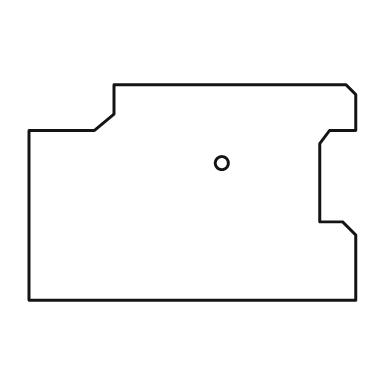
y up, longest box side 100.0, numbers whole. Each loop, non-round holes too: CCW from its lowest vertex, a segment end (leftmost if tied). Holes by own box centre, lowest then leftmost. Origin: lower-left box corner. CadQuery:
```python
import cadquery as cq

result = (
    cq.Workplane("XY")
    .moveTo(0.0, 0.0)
    .lineTo(100.0, 0.0)
    .lineTo(100.0, 20.0)
    .lineTo(96.0, 24.0)
    .lineTo(89.0, 24.0)
    .lineTo(89.0, 48.0)
    .lineTo(92.0, 52.0)
    .lineTo(100.0, 52.0)
    .lineTo(100.0, 63.0)
    .lineTo(97.0, 66.0)
    .lineTo(26.0, 66.0)
    .lineTo(26.0, 57.0)
    .lineTo(20.0, 52.0)
    .lineTo(0.0, 52.0)
    .close()
    .moveTo(59.0, 42.0)
    .circle(2.0)
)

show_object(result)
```